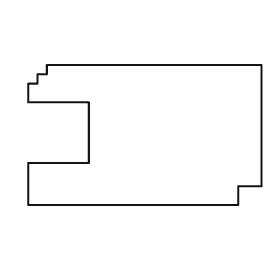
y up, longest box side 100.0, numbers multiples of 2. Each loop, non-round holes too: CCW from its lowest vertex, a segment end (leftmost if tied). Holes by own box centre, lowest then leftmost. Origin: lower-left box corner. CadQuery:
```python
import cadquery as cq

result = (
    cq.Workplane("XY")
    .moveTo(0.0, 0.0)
    .lineTo(90.0, 0.0)
    .lineTo(90.0, 8.0)
    .lineTo(100.0, 8.0)
    .lineTo(100.0, 60.0)
    .lineTo(8.0, 60.0)
    .lineTo(8.0, 56.0)
    .lineTo(4.0, 56.0)
    .lineTo(4.0, 52.0)
    .lineTo(0.0, 52.0)
    .lineTo(0.0, 44.0)
    .lineTo(26.0, 44.0)
    .lineTo(26.0, 18.0)
    .lineTo(0.0, 18.0)
    .close()
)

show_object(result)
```